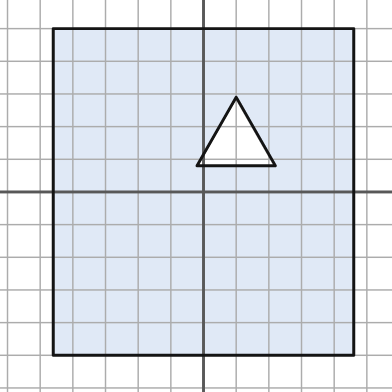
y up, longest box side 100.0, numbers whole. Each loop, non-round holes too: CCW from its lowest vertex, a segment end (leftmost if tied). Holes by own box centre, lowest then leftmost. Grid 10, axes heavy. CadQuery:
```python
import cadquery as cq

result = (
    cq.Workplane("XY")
    .moveTo(-46.0, -50.0)
    .lineTo(46.0, -50.0)
    .lineTo(46.0, 50.0)
    .lineTo(-46.0, 50.0)
    .close()
    .moveTo(-2.0, 8.0)
    .lineTo(22.0, 8.0)
    .lineTo(10.0, 29.0)
    .close()
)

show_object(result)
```